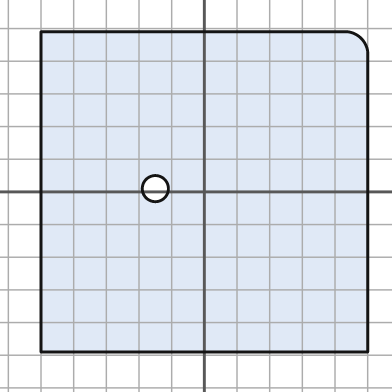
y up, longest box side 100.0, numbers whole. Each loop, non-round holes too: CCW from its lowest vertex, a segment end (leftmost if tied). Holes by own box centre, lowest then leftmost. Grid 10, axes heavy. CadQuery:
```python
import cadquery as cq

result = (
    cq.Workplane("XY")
    .moveTo(-50.0, -49.0)
    .lineTo(50.0, -49.0)
    .lineTo(50.0, 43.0)
    .threePointArc((48.0, 47.0), (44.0, 49.0))
    .lineTo(-50.0, 49.0)
    .close()
    .moveTo(-15.0, 1.0)
    .circle(4.0)
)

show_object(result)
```